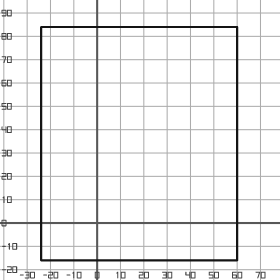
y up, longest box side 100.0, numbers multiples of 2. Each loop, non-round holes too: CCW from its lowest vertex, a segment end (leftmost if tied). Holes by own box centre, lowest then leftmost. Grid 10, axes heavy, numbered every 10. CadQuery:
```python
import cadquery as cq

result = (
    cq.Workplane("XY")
    .moveTo(-24.0, -16.0)
    .lineTo(60.0, -16.0)
    .lineTo(60.0, 84.0)
    .lineTo(-24.0, 84.0)
    .close()
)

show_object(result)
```